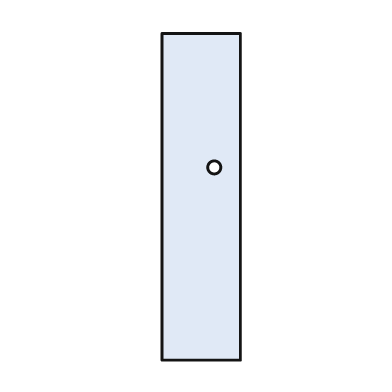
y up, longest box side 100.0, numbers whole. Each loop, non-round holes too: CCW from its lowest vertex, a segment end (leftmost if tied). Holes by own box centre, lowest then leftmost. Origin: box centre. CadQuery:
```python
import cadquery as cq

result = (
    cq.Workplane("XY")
    .moveTo(-12.0, -50.0)
    .lineTo(12.0, -50.0)
    .lineTo(12.0, 50.0)
    .lineTo(-12.0, 50.0)
    .close()
    .moveTo(4.0, 9.0)
    .circle(2.0)
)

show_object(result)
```